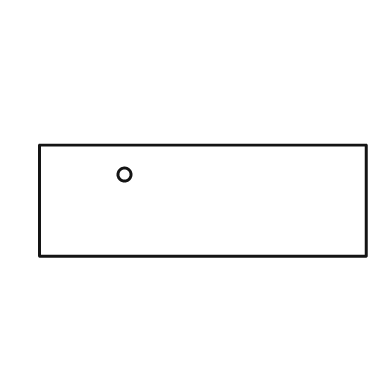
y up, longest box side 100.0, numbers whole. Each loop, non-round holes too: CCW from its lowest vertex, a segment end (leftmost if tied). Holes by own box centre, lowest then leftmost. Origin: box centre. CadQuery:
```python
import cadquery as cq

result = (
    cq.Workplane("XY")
    .moveTo(-50.0, -17.0)
    .lineTo(50.0, -17.0)
    .lineTo(50.0, 17.0)
    .lineTo(-50.0, 17.0)
    .close()
    .moveTo(-24.0, 8.0)
    .circle(2.0)
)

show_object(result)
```